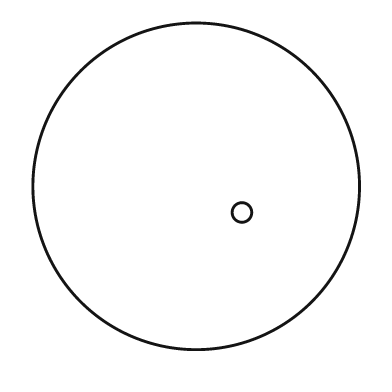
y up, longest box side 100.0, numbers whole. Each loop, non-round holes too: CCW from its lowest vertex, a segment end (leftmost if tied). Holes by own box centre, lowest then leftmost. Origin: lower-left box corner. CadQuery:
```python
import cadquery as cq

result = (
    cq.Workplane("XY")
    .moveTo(50.0, 50.0)
    .circle(50.0)
    .moveTo(64.0, 42.0)
    .circle(3.0)
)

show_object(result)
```